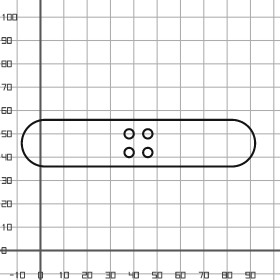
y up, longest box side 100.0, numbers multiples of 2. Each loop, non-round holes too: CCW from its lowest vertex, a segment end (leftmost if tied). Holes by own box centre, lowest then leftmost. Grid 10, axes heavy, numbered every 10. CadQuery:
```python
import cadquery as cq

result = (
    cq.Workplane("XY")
    .moveTo(2.0, 36.0)
    .lineTo(82.0, 36.0)
    .threePointArc((92.0, 46.0), (82.0, 56.0))
    .lineTo(2.0, 56.0)
    .threePointArc((-8.0, 46.0), (2.0, 36.0))
    .close()
    .moveTo(38.0, 42.0)
    .circle(2.0)
    .moveTo(46.0, 42.0)
    .circle(2.0)
    .moveTo(38.0, 50.0)
    .circle(2.0)
    .moveTo(46.0, 50.0)
    .circle(2.0)
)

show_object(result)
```